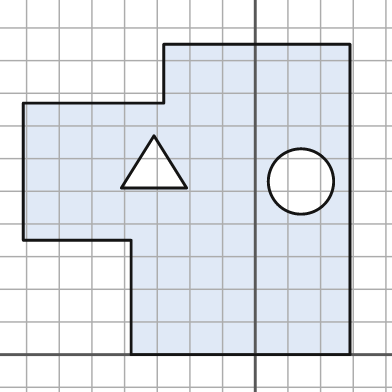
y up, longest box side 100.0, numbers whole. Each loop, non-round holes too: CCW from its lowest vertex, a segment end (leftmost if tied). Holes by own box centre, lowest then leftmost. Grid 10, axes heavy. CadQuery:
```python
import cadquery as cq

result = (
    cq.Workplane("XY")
    .moveTo(-38.0, 0.0)
    .lineTo(29.0, 0.0)
    .lineTo(29.0, 95.0)
    .lineTo(-28.0, 95.0)
    .lineTo(-28.0, 77.0)
    .lineTo(-71.0, 77.0)
    .lineTo(-71.0, 35.0)
    .lineTo(-38.0, 35.0)
    .close()
    .moveTo(14.0, 53.0)
    .circle(10.0)
    .moveTo(-41.0, 51.0)
    .lineTo(-21.0, 51.0)
    .lineTo(-31.0, 67.0)
    .close()
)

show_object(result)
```